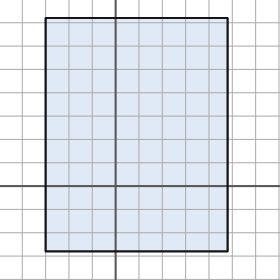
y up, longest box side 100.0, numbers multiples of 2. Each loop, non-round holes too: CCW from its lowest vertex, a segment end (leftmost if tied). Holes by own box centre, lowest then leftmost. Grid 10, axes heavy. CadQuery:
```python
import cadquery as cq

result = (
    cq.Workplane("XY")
    .moveTo(-30.0, -28.0)
    .lineTo(48.0, -28.0)
    .lineTo(48.0, 72.0)
    .lineTo(-30.0, 72.0)
    .close()
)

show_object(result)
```